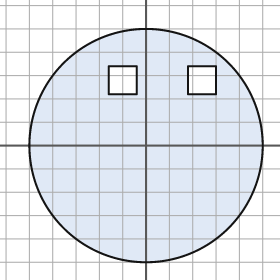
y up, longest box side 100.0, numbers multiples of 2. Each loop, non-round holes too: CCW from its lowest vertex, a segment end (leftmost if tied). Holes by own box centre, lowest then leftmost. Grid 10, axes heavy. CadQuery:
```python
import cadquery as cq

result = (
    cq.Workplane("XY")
    .moveTo(0.0, 0.0)
    .circle(50.0)
    .moveTo(-16.0, 22.0)
    .lineTo(-4.0, 22.0)
    .lineTo(-4.0, 34.0)
    .lineTo(-16.0, 34.0)
    .close()
    .moveTo(18.0, 22.0)
    .lineTo(30.0, 22.0)
    .lineTo(30.0, 34.0)
    .lineTo(18.0, 34.0)
    .close()
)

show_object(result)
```